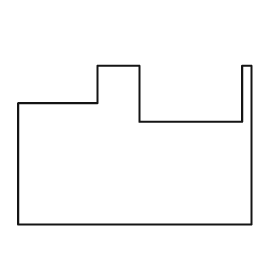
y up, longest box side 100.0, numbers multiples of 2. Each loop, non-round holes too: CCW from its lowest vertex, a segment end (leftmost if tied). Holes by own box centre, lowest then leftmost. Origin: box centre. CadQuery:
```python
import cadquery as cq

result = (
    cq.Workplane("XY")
    .moveTo(-50.0, -34.0)
    .lineTo(50.0, -34.0)
    .lineTo(50.0, 34.0)
    .lineTo(46.0, 34.0)
    .lineTo(46.0, 10.0)
    .lineTo(2.0, 10.0)
    .lineTo(2.0, 34.0)
    .lineTo(-16.0, 34.0)
    .lineTo(-16.0, 18.0)
    .lineTo(-50.0, 18.0)
    .close()
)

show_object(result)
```